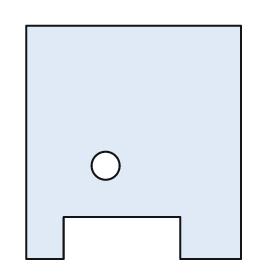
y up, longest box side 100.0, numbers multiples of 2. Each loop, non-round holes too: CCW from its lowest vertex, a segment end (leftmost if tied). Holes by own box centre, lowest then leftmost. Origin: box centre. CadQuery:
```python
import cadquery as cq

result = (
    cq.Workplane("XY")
    .moveTo(-46.0, -50.0)
    .lineTo(-30.0, -50.0)
    .lineTo(-30.0, -32.0)
    .lineTo(20.0, -32.0)
    .lineTo(20.0, -50.0)
    .lineTo(46.0, -50.0)
    .lineTo(46.0, 50.0)
    .lineTo(-46.0, 50.0)
    .close()
    .moveTo(-12.0, -10.0)
    .circle(6.0)
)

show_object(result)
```